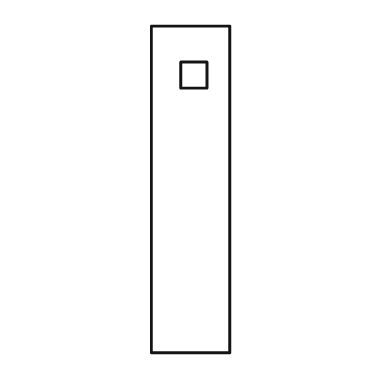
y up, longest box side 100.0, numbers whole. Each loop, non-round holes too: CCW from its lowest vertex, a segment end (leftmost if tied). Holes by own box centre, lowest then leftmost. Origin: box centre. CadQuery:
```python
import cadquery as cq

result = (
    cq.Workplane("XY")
    .moveTo(-12.0, -50.0)
    .lineTo(12.0, -50.0)
    .lineTo(12.0, 50.0)
    .lineTo(-12.0, 50.0)
    .close()
    .moveTo(-3.0, 31.0)
    .lineTo(5.0, 31.0)
    .lineTo(5.0, 39.0)
    .lineTo(-3.0, 39.0)
    .close()
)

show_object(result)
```